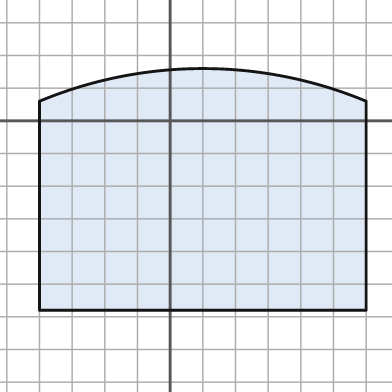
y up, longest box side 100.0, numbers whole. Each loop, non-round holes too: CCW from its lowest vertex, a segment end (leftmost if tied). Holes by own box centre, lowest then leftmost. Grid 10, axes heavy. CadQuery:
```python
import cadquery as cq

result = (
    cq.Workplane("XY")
    .moveTo(-40.0, -58.0)
    .lineTo(60.0, -58.0)
    .lineTo(60.0, 6.0)
    .threePointArc((10.0, 16.0), (-40.0, 6.0))
    .close()
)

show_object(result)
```